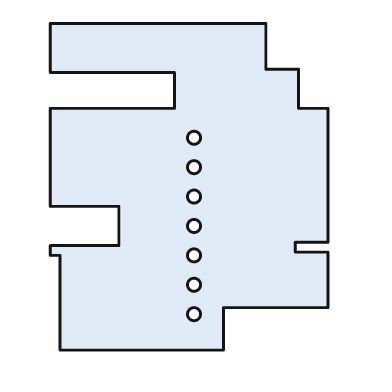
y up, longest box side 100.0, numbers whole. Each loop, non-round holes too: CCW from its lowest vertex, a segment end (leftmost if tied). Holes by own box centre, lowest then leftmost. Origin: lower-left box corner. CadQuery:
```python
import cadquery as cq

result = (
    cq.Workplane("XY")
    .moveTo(3.0, 0.0)
    .lineTo(53.0, 0.0)
    .lineTo(53.0, 13.0)
    .lineTo(85.0, 13.0)
    .lineTo(85.0, 30.0)
    .lineTo(75.0, 30.0)
    .lineTo(75.0, 33.0)
    .lineTo(85.0, 33.0)
    .lineTo(85.0, 74.0)
    .lineTo(76.0, 74.0)
    .lineTo(76.0, 86.0)
    .lineTo(66.0, 86.0)
    .lineTo(66.0, 100.0)
    .lineTo(0.0, 100.0)
    .lineTo(0.0, 85.0)
    .lineTo(38.0, 85.0)
    .lineTo(38.0, 74.0)
    .lineTo(0.0, 74.0)
    .lineTo(0.0, 44.0)
    .lineTo(21.0, 44.0)
    .lineTo(21.0, 32.0)
    .lineTo(0.0, 32.0)
    .lineTo(0.0, 29.0)
    .lineTo(3.0, 29.0)
    .close()
    .moveTo(44.0, 11.0)
    .circle(2.0)
    .moveTo(44.0, 20.0)
    .circle(2.0)
    .moveTo(44.0, 29.0)
    .circle(2.0)
    .moveTo(44.0, 38.0)
    .circle(2.0)
    .moveTo(44.0, 47.0)
    .circle(2.0)
    .moveTo(44.0, 56.0)
    .circle(2.0)
    .moveTo(44.0, 65.0)
    .circle(2.0)
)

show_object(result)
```